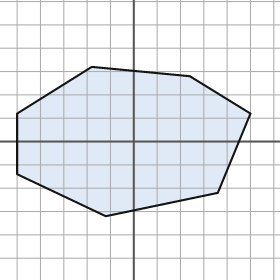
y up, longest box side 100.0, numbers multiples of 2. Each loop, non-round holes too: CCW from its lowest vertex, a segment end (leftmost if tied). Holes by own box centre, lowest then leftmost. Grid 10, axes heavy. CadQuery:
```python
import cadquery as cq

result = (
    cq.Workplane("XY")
    .moveTo(-12.0, -32.0)
    .lineTo(36.0, -22.0)
    .lineTo(50.0, 12.0)
    .lineTo(24.0, 28.0)
    .lineTo(-18.0, 32.0)
    .lineTo(-50.0, 12.0)
    .lineTo(-50.0, -14.0)
    .close()
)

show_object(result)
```